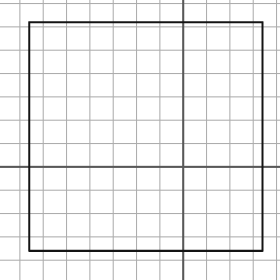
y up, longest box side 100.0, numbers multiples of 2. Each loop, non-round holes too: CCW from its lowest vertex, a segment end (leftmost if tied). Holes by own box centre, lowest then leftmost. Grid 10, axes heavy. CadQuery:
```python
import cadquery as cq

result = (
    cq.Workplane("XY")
    .moveTo(-66.0, -36.0)
    .lineTo(34.0, -36.0)
    .lineTo(34.0, 62.0)
    .lineTo(-66.0, 62.0)
    .close()
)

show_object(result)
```